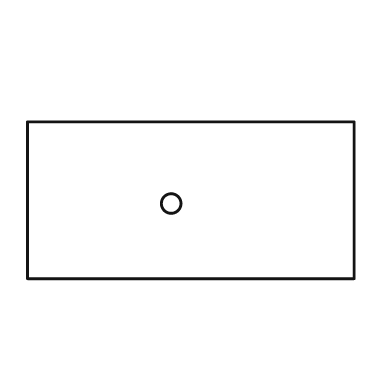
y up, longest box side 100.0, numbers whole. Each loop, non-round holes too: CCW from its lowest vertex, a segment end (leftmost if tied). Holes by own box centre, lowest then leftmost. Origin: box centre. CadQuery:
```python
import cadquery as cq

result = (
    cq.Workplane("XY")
    .moveTo(-50.0, -24.0)
    .lineTo(50.0, -24.0)
    .lineTo(50.0, 24.0)
    .lineTo(-50.0, 24.0)
    .close()
    .moveTo(-6.0, -1.0)
    .circle(3.0)
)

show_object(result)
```